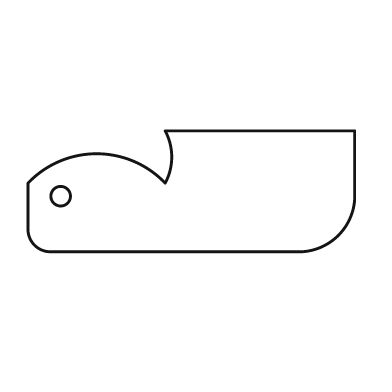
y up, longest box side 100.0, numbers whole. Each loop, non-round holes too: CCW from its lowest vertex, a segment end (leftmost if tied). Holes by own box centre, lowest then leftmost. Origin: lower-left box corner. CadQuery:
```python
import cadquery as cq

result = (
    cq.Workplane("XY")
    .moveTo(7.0, 0.0)
    .lineTo(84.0, 0.0)
    .threePointArc((95.0, 5.0), (100.0, 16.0))
    .lineTo(100.0, 37.0)
    .lineTo(42.0, 37.0)
    .threePointArc((44.0, 29.0), (42.0, 21.0))
    .threePointArc((21.0, 30.0), (0.0, 21.0))
    .lineTo(0.0, 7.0)
    .threePointArc((2.0, 2.0), (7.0, 0.0))
    .close()
    .moveTo(10.0, 17.0)
    .circle(3.0)
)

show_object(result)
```